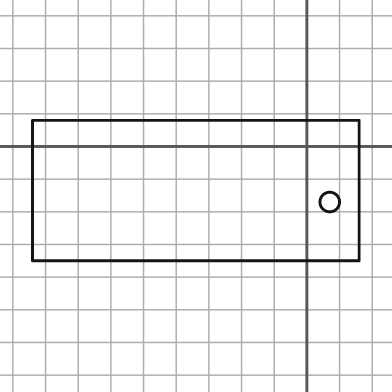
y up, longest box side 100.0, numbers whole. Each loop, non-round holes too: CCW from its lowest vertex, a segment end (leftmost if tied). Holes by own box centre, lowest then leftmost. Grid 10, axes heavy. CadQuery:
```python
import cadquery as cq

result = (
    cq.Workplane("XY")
    .moveTo(-84.0, -35.0)
    .lineTo(16.0, -35.0)
    .lineTo(16.0, 8.0)
    .lineTo(-84.0, 8.0)
    .close()
    .moveTo(7.0, -17.0)
    .circle(3.0)
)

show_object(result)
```